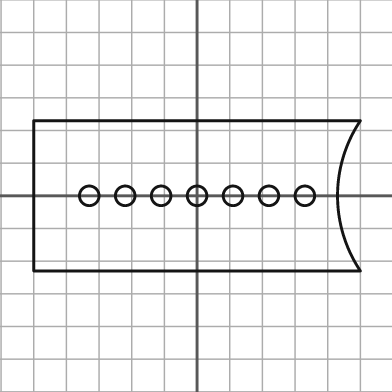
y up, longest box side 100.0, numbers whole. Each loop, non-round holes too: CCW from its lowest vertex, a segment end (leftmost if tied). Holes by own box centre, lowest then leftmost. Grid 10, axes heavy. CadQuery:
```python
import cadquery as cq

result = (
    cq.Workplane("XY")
    .moveTo(-50.0, -23.0)
    .lineTo(50.0, -23.0)
    .threePointArc((43.0, 0.0), (50.0, 23.0))
    .lineTo(-50.0, 23.0)
    .close()
    .moveTo(-33.0, 0.0)
    .circle(3.0)
    .moveTo(-22.0, 0.0)
    .circle(3.0)
    .moveTo(-11.0, 0.0)
    .circle(3.0)
    .moveTo(0.0, 0.0)
    .circle(3.0)
    .moveTo(11.0, 0.0)
    .circle(3.0)
    .moveTo(22.0, 0.0)
    .circle(3.0)
    .moveTo(33.0, 0.0)
    .circle(3.0)
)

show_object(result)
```